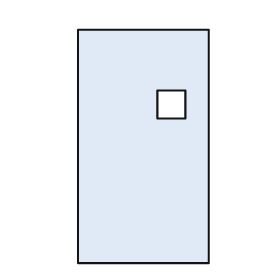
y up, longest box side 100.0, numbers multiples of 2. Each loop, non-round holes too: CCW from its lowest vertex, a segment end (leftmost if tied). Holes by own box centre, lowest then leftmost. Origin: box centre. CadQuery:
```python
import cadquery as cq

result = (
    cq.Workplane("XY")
    .moveTo(-28.0, -50.0)
    .lineTo(28.0, -50.0)
    .lineTo(28.0, 50.0)
    .lineTo(-28.0, 50.0)
    .close()
    .moveTo(6.0, 12.0)
    .lineTo(18.0, 12.0)
    .lineTo(18.0, 24.0)
    .lineTo(6.0, 24.0)
    .close()
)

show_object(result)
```